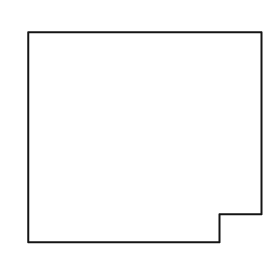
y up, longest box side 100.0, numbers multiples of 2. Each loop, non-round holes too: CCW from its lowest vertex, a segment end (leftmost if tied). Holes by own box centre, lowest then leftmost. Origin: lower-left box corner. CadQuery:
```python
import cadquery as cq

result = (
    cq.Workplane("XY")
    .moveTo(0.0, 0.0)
    .lineTo(82.0, 0.0)
    .lineTo(82.0, 12.0)
    .lineTo(100.0, 12.0)
    .lineTo(100.0, 90.0)
    .lineTo(0.0, 90.0)
    .close()
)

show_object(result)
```